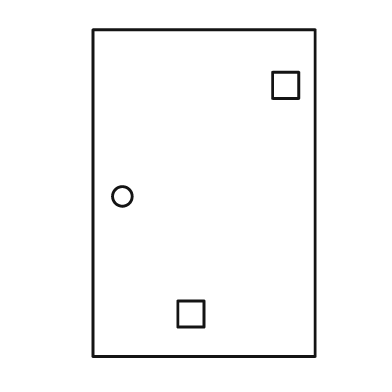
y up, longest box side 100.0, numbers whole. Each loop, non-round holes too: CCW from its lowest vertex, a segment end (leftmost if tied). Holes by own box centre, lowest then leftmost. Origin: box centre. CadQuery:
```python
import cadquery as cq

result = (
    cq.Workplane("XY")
    .moveTo(-34.0, -50.0)
    .lineTo(34.0, -50.0)
    .lineTo(34.0, 50.0)
    .lineTo(-34.0, 50.0)
    .close()
    .moveTo(-8.0, -41.0)
    .lineTo(0.0, -41.0)
    .lineTo(0.0, -33.0)
    .lineTo(-8.0, -33.0)
    .close()
    .moveTo(-25.0, -1.0)
    .circle(3.0)
    .moveTo(21.0, 29.0)
    .lineTo(29.0, 29.0)
    .lineTo(29.0, 37.0)
    .lineTo(21.0, 37.0)
    .close()
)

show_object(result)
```